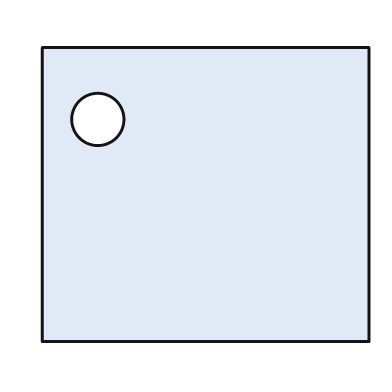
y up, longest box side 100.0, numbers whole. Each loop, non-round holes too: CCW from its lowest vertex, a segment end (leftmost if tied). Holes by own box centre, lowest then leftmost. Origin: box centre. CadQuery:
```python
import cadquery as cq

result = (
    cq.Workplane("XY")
    .moveTo(-50.0, -45.0)
    .lineTo(50.0, -45.0)
    .lineTo(50.0, 45.0)
    .lineTo(-50.0, 45.0)
    .close()
    .moveTo(-33.0, 23.0)
    .circle(8.0)
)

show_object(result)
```